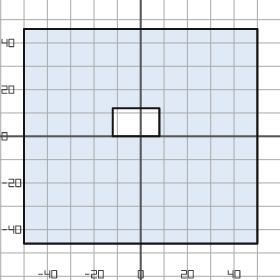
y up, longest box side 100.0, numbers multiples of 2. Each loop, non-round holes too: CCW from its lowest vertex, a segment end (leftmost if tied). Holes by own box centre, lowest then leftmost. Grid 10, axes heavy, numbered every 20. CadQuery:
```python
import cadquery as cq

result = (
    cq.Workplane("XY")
    .moveTo(-50.0, -46.0)
    .lineTo(50.0, -46.0)
    .lineTo(50.0, 46.0)
    .lineTo(-50.0, 46.0)
    .close()
    .moveTo(-12.0, 0.0)
    .lineTo(8.0, 0.0)
    .lineTo(8.0, 12.0)
    .lineTo(-12.0, 12.0)
    .close()
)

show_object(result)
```